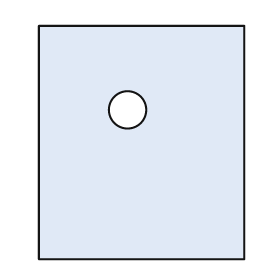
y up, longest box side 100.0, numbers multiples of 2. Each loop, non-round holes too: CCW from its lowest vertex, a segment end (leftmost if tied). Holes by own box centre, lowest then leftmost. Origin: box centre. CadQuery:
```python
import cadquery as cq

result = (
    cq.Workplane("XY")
    .moveTo(-44.0, -50.0)
    .lineTo(44.0, -50.0)
    .lineTo(44.0, 50.0)
    .lineTo(-44.0, 50.0)
    .close()
    .moveTo(-6.0, 14.0)
    .circle(8.0)
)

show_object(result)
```